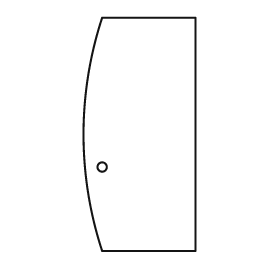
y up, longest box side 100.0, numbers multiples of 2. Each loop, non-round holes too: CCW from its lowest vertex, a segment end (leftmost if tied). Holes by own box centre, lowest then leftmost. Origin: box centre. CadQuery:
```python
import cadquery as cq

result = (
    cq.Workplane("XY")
    .moveTo(-16.0, -50.0)
    .lineTo(24.0, -50.0)
    .lineTo(24.0, 50.0)
    .lineTo(-16.0, 50.0)
    .threePointArc((-24.0, 0.0), (-16.0, -50.0))
    .close()
    .moveTo(-16.0, -14.0)
    .circle(2.0)
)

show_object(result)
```